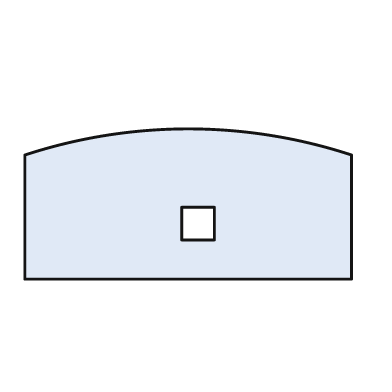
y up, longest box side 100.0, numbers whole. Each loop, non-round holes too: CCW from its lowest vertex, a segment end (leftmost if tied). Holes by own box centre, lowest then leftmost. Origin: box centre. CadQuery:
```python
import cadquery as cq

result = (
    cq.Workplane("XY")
    .moveTo(-50.0, -23.0)
    .lineTo(50.0, -23.0)
    .lineTo(50.0, 15.0)
    .threePointArc((0.0, 23.0), (-50.0, 15.0))
    .close()
    .moveTo(-2.0, -11.0)
    .lineTo(8.0, -11.0)
    .lineTo(8.0, -1.0)
    .lineTo(-2.0, -1.0)
    .close()
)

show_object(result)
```